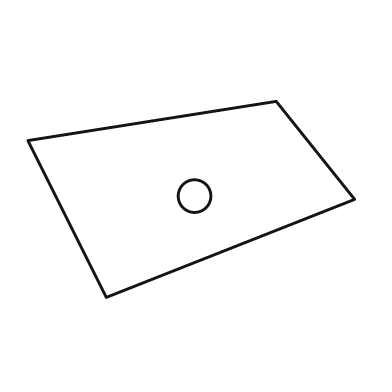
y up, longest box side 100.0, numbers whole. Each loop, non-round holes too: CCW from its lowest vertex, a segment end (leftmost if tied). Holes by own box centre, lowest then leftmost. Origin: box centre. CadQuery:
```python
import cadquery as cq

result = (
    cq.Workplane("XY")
    .moveTo(-26.0, -30.0)
    .lineTo(50.0, 0.0)
    .lineTo(26.0, 30.0)
    .lineTo(-50.0, 18.0)
    .close()
    .moveTo(1.0, 1.0)
    .circle(5.0)
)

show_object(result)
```